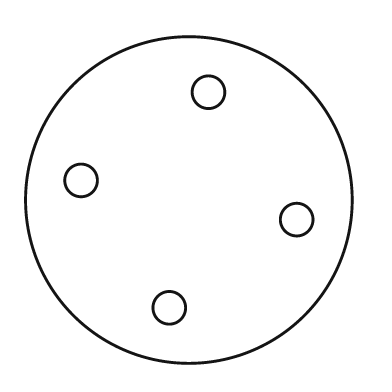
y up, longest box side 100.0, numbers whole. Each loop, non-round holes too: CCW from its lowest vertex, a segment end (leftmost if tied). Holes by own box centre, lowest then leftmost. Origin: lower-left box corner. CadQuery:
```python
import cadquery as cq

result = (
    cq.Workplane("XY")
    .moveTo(50.0, 50.0)
    .circle(50.0)
    .moveTo(44.0, 17.0)
    .circle(5.0)
    .moveTo(83.0, 44.0)
    .circle(5.0)
    .moveTo(17.0, 56.0)
    .circle(5.0)
    .moveTo(56.0, 83.0)
    .circle(5.0)
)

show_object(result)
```